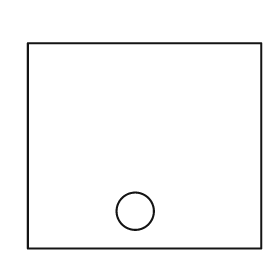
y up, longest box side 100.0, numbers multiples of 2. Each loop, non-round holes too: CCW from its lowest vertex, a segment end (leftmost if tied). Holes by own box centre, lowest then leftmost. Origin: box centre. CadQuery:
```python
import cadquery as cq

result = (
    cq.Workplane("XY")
    .moveTo(-50.0, -44.0)
    .lineTo(50.0, -44.0)
    .lineTo(50.0, 44.0)
    .lineTo(-50.0, 44.0)
    .close()
    .moveTo(-4.0, -28.0)
    .circle(8.0)
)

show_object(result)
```